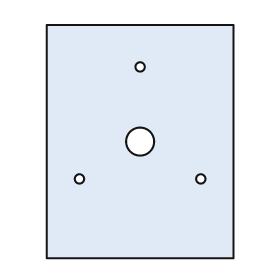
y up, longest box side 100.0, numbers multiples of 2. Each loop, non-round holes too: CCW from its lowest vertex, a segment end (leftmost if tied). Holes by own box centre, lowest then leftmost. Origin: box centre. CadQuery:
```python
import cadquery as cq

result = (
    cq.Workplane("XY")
    .moveTo(-40.0, -50.0)
    .lineTo(40.0, -50.0)
    .lineTo(40.0, 50.0)
    .lineTo(-40.0, 50.0)
    .close()
    .moveTo(-26.0, -16.0)
    .circle(2.0)
    .moveTo(26.0, -16.0)
    .circle(2.0)
    .moveTo(0.0, 0.0)
    .circle(6.0)
    .moveTo(0.0, 32.0)
    .circle(2.0)
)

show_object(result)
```